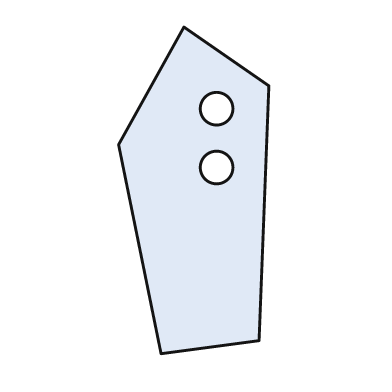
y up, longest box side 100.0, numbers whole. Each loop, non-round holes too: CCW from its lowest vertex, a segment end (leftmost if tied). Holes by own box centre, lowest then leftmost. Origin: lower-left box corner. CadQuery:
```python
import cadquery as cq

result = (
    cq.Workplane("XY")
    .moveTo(13.0, 0.0)
    .lineTo(43.0, 4.0)
    .lineTo(46.0, 82.0)
    .lineTo(20.0, 100.0)
    .lineTo(0.0, 64.0)
    .close()
    .moveTo(30.0, 57.0)
    .circle(5.0)
    .moveTo(30.0, 75.0)
    .circle(5.0)
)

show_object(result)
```